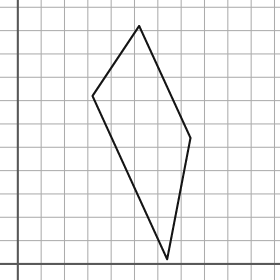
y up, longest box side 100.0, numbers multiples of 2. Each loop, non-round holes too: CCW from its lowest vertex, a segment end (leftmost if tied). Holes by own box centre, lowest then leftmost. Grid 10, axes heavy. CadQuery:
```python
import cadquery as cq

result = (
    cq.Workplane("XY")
    .moveTo(64.0, 2.0)
    .lineTo(74.0, 54.0)
    .lineTo(52.0, 102.0)
    .lineTo(32.0, 72.0)
    .close()
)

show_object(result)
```